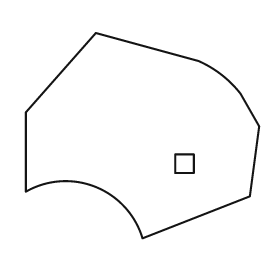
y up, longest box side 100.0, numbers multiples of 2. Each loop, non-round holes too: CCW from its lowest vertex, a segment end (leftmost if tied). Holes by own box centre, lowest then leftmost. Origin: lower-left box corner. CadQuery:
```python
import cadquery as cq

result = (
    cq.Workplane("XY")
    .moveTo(50.0, 0.0)
    .lineTo(96.0, 18.0)
    .lineTo(100.0, 48.0)
    .lineTo(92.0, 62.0)
    .threePointArc((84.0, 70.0), (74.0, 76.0))
    .lineTo(30.0, 88.0)
    .lineTo(0.0, 54.0)
    .lineTo(0.0, 20.0)
    .threePointArc((30.0, 22.0), (50.0, 0.0))
    .close()
    .moveTo(64.0, 28.0)
    .lineTo(72.0, 28.0)
    .lineTo(72.0, 36.0)
    .lineTo(64.0, 36.0)
    .close()
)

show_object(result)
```